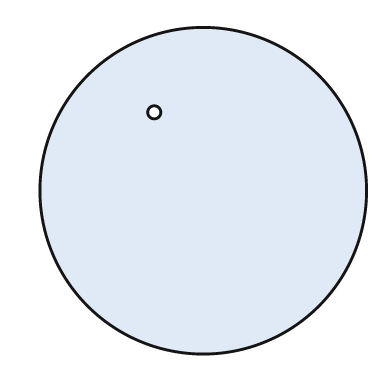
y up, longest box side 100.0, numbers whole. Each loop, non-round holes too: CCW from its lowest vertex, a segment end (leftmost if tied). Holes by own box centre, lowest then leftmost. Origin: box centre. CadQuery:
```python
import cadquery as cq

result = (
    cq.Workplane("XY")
    .moveTo(0.0, 0.0)
    .circle(50.0)
    .moveTo(-15.0, 24.0)
    .circle(2.0)
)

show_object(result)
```